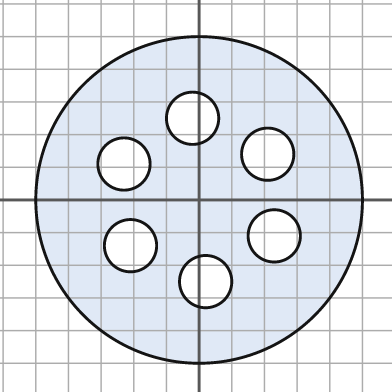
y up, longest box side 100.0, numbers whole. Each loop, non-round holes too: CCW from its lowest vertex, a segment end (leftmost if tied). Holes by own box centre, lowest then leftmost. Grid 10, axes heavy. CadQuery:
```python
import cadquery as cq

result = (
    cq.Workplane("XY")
    .moveTo(0.0, 0.0)
    .circle(50.0)
    .moveTo(2.0, -25.0)
    .circle(8.0)
    .moveTo(-21.0, -14.0)
    .circle(8.0)
    .moveTo(23.0, -11.0)
    .circle(8.0)
    .moveTo(-23.0, 11.0)
    .circle(8.0)
    .moveTo(21.0, 14.0)
    .circle(8.0)
    .moveTo(-2.0, 25.0)
    .circle(8.0)
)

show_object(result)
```